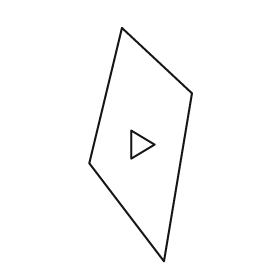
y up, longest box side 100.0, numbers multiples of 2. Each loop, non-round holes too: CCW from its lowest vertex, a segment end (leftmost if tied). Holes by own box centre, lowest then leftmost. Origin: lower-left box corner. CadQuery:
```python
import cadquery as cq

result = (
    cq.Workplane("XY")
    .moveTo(32.0, 0.0)
    .lineTo(44.0, 72.0)
    .lineTo(14.0, 100.0)
    .lineTo(0.0, 42.0)
    .close()
    .moveTo(18.0, 44.0)
    .lineTo(28.0, 50.0)
    .lineTo(18.0, 56.0)
    .close()
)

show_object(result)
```